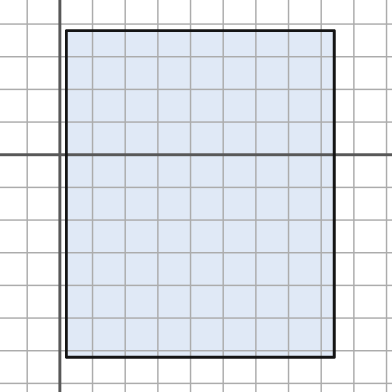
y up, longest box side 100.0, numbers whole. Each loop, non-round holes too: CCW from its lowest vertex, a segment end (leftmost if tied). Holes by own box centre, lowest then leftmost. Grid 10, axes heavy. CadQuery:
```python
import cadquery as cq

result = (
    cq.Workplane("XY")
    .moveTo(2.0, -62.0)
    .lineTo(84.0, -62.0)
    .lineTo(84.0, 38.0)
    .lineTo(2.0, 38.0)
    .close()
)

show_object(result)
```